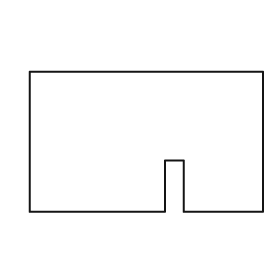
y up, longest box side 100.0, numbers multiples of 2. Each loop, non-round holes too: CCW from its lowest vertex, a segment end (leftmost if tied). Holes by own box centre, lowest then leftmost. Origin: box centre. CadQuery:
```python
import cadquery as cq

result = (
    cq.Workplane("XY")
    .moveTo(-50.0, -30.0)
    .lineTo(8.0, -30.0)
    .lineTo(8.0, -8.0)
    .lineTo(16.0, -8.0)
    .lineTo(16.0, -30.0)
    .lineTo(50.0, -30.0)
    .lineTo(50.0, 30.0)
    .lineTo(-50.0, 30.0)
    .close()
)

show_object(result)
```